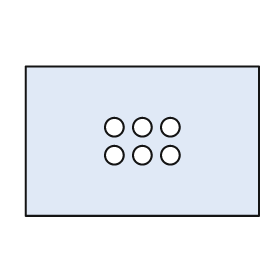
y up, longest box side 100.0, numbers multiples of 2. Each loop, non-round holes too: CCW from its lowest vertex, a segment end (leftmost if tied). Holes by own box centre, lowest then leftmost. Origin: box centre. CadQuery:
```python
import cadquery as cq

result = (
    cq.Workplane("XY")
    .moveTo(-50.0, -32.0)
    .lineTo(50.0, -32.0)
    .lineTo(50.0, 32.0)
    .lineTo(-50.0, 32.0)
    .close()
    .moveTo(-12.0, -6.0)
    .circle(4.0)
    .moveTo(0.0, -6.0)
    .circle(4.0)
    .moveTo(12.0, -6.0)
    .circle(4.0)
    .moveTo(-12.0, 6.0)
    .circle(4.0)
    .moveTo(0.0, 6.0)
    .circle(4.0)
    .moveTo(12.0, 6.0)
    .circle(4.0)
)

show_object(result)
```